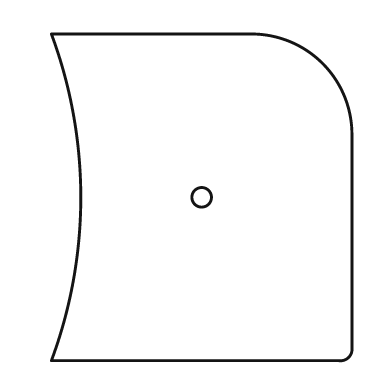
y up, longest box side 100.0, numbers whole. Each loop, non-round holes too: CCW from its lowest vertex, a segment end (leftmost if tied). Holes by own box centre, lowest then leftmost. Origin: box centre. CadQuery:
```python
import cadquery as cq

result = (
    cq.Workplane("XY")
    .moveTo(-46.0, -50.0)
    .lineTo(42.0, -50.0)
    .threePointArc((45.0, -49.0), (46.0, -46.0))
    .lineTo(46.0, 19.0)
    .threePointArc((37.0, 41.0), (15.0, 50.0))
    .lineTo(-46.0, 50.0)
    .threePointArc((-37.0, 0.0), (-46.0, -50.0))
    .close()
    .moveTo(0.0, 0.0)
    .circle(3.0)
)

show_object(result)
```